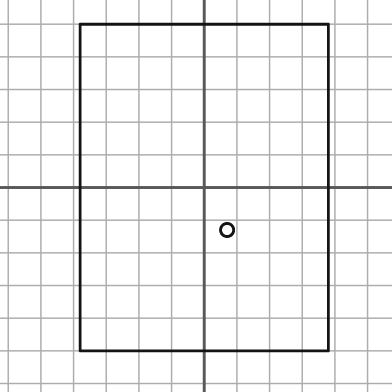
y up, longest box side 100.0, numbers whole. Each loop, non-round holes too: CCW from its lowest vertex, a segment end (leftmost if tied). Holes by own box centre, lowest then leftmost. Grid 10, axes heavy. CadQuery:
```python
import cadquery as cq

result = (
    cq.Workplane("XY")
    .moveTo(-38.0, -50.0)
    .lineTo(38.0, -50.0)
    .lineTo(38.0, 50.0)
    .lineTo(-38.0, 50.0)
    .close()
    .moveTo(7.0, -13.0)
    .circle(2.0)
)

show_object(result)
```